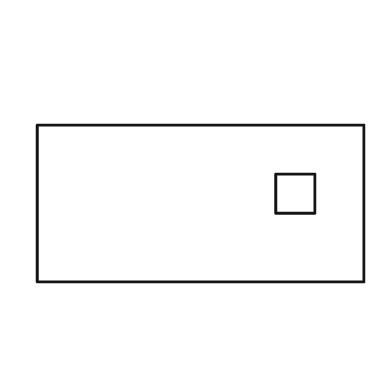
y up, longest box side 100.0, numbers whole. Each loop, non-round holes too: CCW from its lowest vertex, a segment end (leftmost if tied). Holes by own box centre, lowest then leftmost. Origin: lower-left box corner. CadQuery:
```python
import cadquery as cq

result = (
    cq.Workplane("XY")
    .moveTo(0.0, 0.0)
    .lineTo(100.0, 0.0)
    .lineTo(100.0, 48.0)
    .lineTo(0.0, 48.0)
    .close()
    .moveTo(73.0, 21.0)
    .lineTo(85.0, 21.0)
    .lineTo(85.0, 33.0)
    .lineTo(73.0, 33.0)
    .close()
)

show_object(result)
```